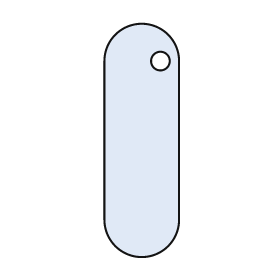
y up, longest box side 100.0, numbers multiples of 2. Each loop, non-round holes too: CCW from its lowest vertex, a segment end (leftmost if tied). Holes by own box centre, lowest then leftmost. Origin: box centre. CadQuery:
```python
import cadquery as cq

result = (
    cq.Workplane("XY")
    .moveTo(-16.0, -34.0)
    .threePointArc((0.0, -50.0), (16.0, -34.0))
    .lineTo(16.0, 34.0)
    .threePointArc((0.0, 50.0), (-16.0, 34.0))
    .close()
    .moveTo(8.0, 34.0)
    .circle(4.0)
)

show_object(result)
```